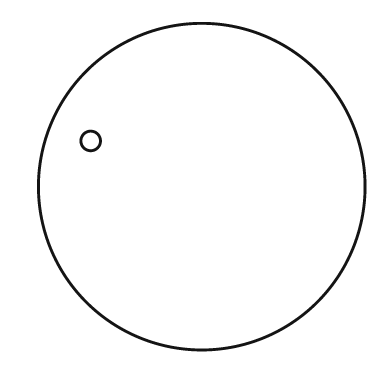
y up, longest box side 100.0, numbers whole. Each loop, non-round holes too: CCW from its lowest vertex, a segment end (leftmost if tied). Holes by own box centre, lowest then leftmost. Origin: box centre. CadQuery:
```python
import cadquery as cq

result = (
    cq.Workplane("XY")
    .moveTo(0.0, 0.0)
    .circle(50.0)
    .moveTo(-34.0, 14.0)
    .circle(3.0)
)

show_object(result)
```